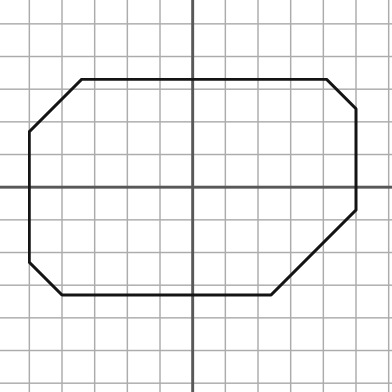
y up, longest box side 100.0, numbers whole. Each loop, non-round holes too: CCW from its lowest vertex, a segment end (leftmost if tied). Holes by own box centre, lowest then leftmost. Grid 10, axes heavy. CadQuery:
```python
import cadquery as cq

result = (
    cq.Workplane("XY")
    .moveTo(-40.0, -33.0)
    .lineTo(24.0, -33.0)
    .lineTo(50.0, -7.0)
    .lineTo(50.0, 24.0)
    .lineTo(41.0, 33.0)
    .lineTo(-34.0, 33.0)
    .lineTo(-50.0, 17.0)
    .lineTo(-50.0, -23.0)
    .close()
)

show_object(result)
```